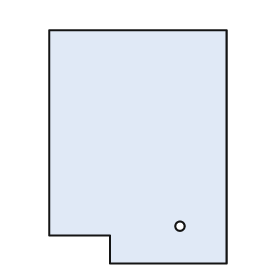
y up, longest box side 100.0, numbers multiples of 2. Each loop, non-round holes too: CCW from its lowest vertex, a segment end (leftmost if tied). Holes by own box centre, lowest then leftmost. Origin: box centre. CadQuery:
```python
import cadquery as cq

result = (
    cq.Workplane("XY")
    .moveTo(-12.0, -50.0)
    .lineTo(38.0, -50.0)
    .lineTo(38.0, 50.0)
    .lineTo(-38.0, 50.0)
    .lineTo(-38.0, -38.0)
    .lineTo(-12.0, -38.0)
    .close()
    .moveTo(18.0, -34.0)
    .circle(2.0)
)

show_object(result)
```